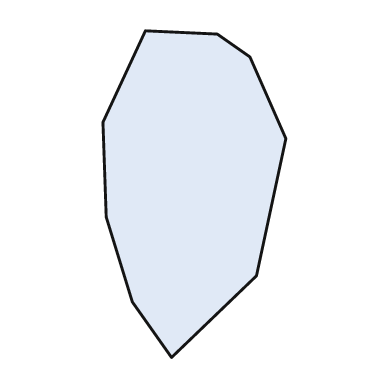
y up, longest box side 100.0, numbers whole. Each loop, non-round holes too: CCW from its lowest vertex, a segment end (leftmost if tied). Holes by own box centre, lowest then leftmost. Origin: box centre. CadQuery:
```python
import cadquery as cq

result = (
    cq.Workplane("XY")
    .moveTo(-7.0, -50.0)
    .lineTo(19.0, -25.0)
    .lineTo(28.0, 17.0)
    .lineTo(17.0, 42.0)
    .lineTo(7.0, 49.0)
    .lineTo(-15.0, 50.0)
    .lineTo(-28.0, 22.0)
    .lineTo(-27.0, -7.0)
    .lineTo(-19.0, -33.0)
    .close()
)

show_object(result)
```